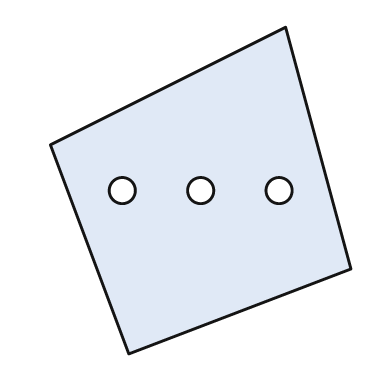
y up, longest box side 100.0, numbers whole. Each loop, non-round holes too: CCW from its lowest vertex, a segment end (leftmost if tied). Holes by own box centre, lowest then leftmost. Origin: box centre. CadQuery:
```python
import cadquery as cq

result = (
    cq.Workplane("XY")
    .moveTo(-22.0, -50.0)
    .lineTo(46.0, -24.0)
    .lineTo(26.0, 50.0)
    .lineTo(-46.0, 14.0)
    .close()
    .moveTo(-24.0, 0.0)
    .circle(4.0)
    .moveTo(0.0, 0.0)
    .circle(4.0)
    .moveTo(24.0, 0.0)
    .circle(4.0)
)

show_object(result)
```